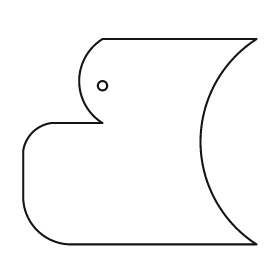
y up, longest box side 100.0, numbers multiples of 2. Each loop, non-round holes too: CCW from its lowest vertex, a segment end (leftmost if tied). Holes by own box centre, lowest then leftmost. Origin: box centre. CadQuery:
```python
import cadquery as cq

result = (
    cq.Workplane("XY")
    .moveTo(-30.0, -44.0)
    .lineTo(50.0, -44.0)
    .threePointArc((26.0, 0.0), (50.0, 44.0))
    .lineTo(-16.0, 44.0)
    .threePointArc((-26.0, 26.0), (-16.0, 8.0))
    .lineTo(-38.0, 8.0)
    .threePointArc((-46.0, 4.0), (-50.0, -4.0))
    .lineTo(-50.0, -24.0)
    .threePointArc((-44.0, -38.0), (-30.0, -44.0))
    .close()
    .moveTo(-16.0, 24.0)
    .circle(2.0)
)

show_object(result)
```